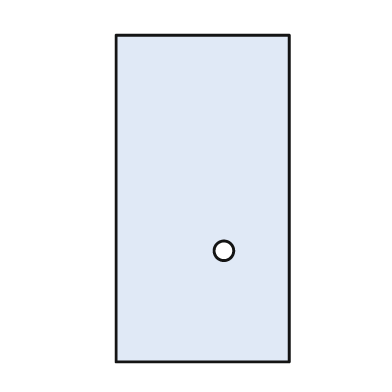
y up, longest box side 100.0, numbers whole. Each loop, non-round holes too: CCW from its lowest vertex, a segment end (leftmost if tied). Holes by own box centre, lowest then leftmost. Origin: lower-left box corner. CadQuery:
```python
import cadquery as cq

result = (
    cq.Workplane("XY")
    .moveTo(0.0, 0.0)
    .lineTo(53.0, 0.0)
    .lineTo(53.0, 100.0)
    .lineTo(0.0, 100.0)
    .close()
    .moveTo(33.0, 34.0)
    .circle(3.0)
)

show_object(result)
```